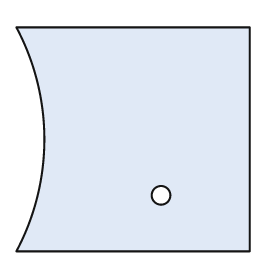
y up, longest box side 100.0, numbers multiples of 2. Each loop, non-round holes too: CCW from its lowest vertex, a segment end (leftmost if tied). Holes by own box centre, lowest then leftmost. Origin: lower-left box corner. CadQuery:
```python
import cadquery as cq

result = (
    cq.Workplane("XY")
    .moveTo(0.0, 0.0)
    .lineTo(100.0, 0.0)
    .lineTo(100.0, 96.0)
    .lineTo(0.0, 96.0)
    .threePointArc((12.0, 48.0), (0.0, 0.0))
    .close()
    .moveTo(62.0, 24.0)
    .circle(4.0)
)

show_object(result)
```